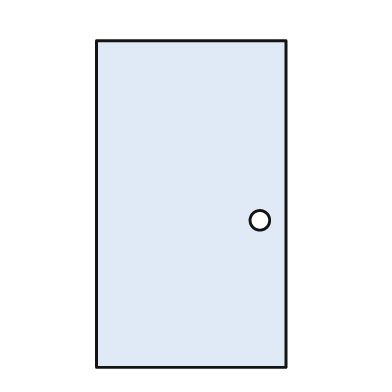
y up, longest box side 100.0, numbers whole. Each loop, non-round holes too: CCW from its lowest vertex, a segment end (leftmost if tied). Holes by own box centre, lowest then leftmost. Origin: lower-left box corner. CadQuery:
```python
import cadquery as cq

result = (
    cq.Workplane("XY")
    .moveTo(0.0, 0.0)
    .lineTo(58.0, 0.0)
    .lineTo(58.0, 100.0)
    .lineTo(0.0, 100.0)
    .close()
    .moveTo(50.0, 45.0)
    .circle(3.0)
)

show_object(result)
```